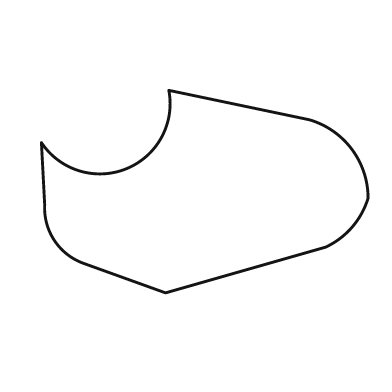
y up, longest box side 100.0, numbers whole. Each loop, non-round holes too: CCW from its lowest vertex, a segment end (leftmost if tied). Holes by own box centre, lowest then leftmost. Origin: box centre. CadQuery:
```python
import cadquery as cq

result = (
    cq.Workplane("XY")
    .moveTo(-12.0, -31.0)
    .lineTo(37.0, -17.0)
    .threePointArc((45.0, -11.0), (50.0, -2.0))
    .threePointArc((45.0, 13.0), (32.0, 22.0))
    .lineTo(-11.0, 31.0)
    .threePointArc((-24.0, 7.0), (-50.0, 15.0))
    .lineTo(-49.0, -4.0)
    .threePointArc((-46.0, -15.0), (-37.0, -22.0))
    .close()
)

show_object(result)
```